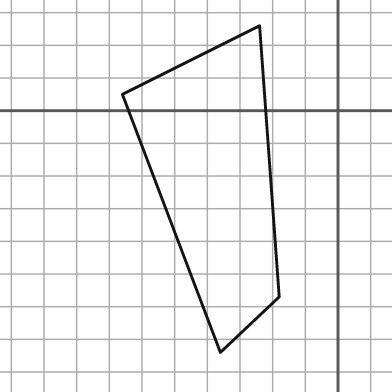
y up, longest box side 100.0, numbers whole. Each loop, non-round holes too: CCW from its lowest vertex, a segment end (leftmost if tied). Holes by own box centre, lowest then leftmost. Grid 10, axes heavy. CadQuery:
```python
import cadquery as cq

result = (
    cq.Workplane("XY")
    .moveTo(-36.0, -74.0)
    .lineTo(-18.0, -57.0)
    .lineTo(-24.0, 26.0)
    .lineTo(-66.0, 5.0)
    .close()
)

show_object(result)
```